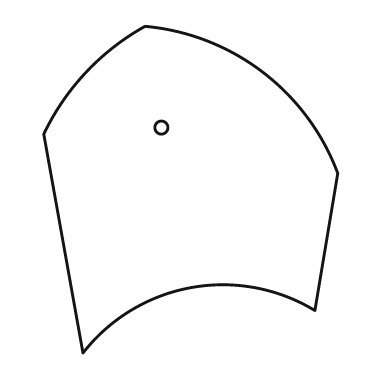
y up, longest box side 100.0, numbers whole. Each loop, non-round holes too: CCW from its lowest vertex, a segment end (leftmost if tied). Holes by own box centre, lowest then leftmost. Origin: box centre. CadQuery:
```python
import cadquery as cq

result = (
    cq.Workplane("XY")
    .moveTo(-33.0, -50.0)
    .threePointArc((0.0, -30.0), (38.0, -37.0))
    .lineTo(45.0, 5.0)
    .threePointArc((22.0, 36.0), (-14.0, 50.0))
    .threePointArc((-32.0, 36.0), (-45.0, 17.0))
    .close()
    .moveTo(-9.0, 19.0)
    .circle(2.0)
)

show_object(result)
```